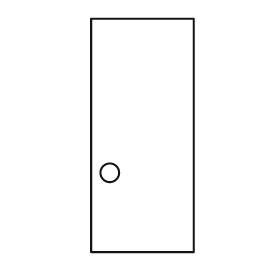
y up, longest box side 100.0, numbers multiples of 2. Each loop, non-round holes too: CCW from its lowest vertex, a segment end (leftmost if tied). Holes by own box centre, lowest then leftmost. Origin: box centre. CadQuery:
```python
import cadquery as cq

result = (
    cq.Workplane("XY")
    .moveTo(-22.0, -50.0)
    .lineTo(22.0, -50.0)
    .lineTo(22.0, 50.0)
    .lineTo(-22.0, 50.0)
    .close()
    .moveTo(-14.0, -16.0)
    .circle(4.0)
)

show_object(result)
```